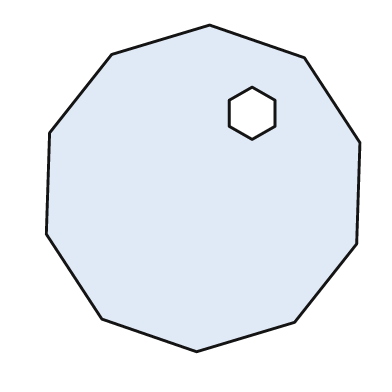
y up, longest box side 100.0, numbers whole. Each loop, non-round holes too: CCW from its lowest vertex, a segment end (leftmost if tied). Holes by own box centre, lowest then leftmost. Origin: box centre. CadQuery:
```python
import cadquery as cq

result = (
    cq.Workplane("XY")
    .moveTo(-2.0, -50.0)
    .lineTo(28.0, -41.0)
    .lineTo(47.0, -17.0)
    .lineTo(48.0, 14.0)
    .lineTo(31.0, 40.0)
    .lineTo(2.0, 50.0)
    .lineTo(-28.0, 41.0)
    .lineTo(-47.0, 17.0)
    .lineTo(-48.0, -14.0)
    .lineTo(-31.0, -40.0)
    .close()
    .moveTo(15.0, 15.0)
    .lineTo(22.0, 19.0)
    .lineTo(22.0, 27.0)
    .lineTo(15.0, 31.0)
    .lineTo(8.0, 27.0)
    .lineTo(8.0, 19.0)
    .close()
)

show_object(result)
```